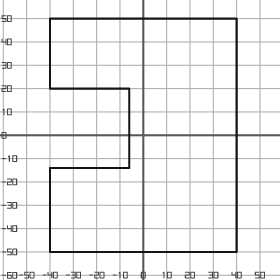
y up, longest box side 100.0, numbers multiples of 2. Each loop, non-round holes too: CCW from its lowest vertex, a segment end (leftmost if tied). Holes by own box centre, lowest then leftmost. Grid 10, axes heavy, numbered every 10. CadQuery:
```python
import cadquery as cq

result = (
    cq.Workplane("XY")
    .moveTo(-40.0, -50.0)
    .lineTo(40.0, -50.0)
    .lineTo(40.0, 50.0)
    .lineTo(-40.0, 50.0)
    .lineTo(-40.0, 20.0)
    .lineTo(-6.0, 20.0)
    .lineTo(-6.0, -14.0)
    .lineTo(-40.0, -14.0)
    .close()
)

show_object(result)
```